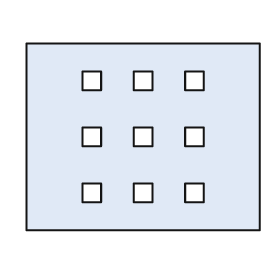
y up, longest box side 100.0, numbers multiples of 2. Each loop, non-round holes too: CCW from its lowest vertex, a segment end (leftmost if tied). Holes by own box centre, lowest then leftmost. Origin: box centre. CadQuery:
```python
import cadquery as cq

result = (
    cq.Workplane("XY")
    .moveTo(-50.0, -40.0)
    .lineTo(50.0, -40.0)
    .lineTo(50.0, 40.0)
    .lineTo(-50.0, 40.0)
    .close()
    .moveTo(-26.0, -28.0)
    .lineTo(-18.0, -28.0)
    .lineTo(-18.0, -20.0)
    .lineTo(-26.0, -20.0)
    .close()
    .moveTo(-4.0, -28.0)
    .lineTo(4.0, -28.0)
    .lineTo(4.0, -20.0)
    .lineTo(-4.0, -20.0)
    .close()
    .moveTo(18.0, -28.0)
    .lineTo(26.0, -28.0)
    .lineTo(26.0, -20.0)
    .lineTo(18.0, -20.0)
    .close()
    .moveTo(-26.0, -4.0)
    .lineTo(-18.0, -4.0)
    .lineTo(-18.0, 4.0)
    .lineTo(-26.0, 4.0)
    .close()
    .moveTo(-4.0, -4.0)
    .lineTo(4.0, -4.0)
    .lineTo(4.0, 4.0)
    .lineTo(-4.0, 4.0)
    .close()
    .moveTo(18.0, -4.0)
    .lineTo(26.0, -4.0)
    .lineTo(26.0, 4.0)
    .lineTo(18.0, 4.0)
    .close()
    .moveTo(-26.0, 20.0)
    .lineTo(-18.0, 20.0)
    .lineTo(-18.0, 28.0)
    .lineTo(-26.0, 28.0)
    .close()
    .moveTo(-4.0, 20.0)
    .lineTo(4.0, 20.0)
    .lineTo(4.0, 28.0)
    .lineTo(-4.0, 28.0)
    .close()
    .moveTo(18.0, 20.0)
    .lineTo(26.0, 20.0)
    .lineTo(26.0, 28.0)
    .lineTo(18.0, 28.0)
    .close()
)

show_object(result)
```